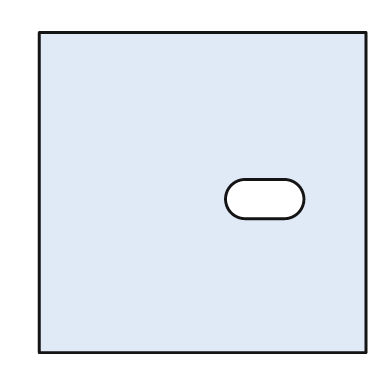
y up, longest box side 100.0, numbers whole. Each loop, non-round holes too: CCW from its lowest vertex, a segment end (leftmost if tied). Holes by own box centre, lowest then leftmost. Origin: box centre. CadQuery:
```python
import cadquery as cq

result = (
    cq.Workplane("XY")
    .moveTo(-50.0, -49.0)
    .lineTo(50.0, -49.0)
    .lineTo(50.0, 49.0)
    .lineTo(-50.0, 49.0)
    .close()
    .moveTo(13.0, -8.0)
    .lineTo(25.0, -8.0)
    .threePointArc((31.0, -2.0), (25.0, 4.0))
    .lineTo(13.0, 4.0)
    .threePointArc((7.0, -2.0), (13.0, -8.0))
    .close()
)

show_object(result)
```